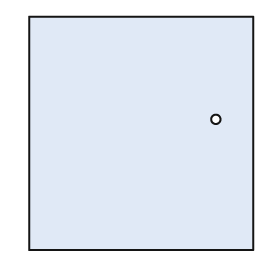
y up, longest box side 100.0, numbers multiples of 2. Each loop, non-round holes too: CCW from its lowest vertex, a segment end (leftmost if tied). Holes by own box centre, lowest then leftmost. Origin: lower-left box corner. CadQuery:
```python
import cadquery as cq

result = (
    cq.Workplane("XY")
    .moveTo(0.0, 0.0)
    .lineTo(96.0, 0.0)
    .lineTo(96.0, 100.0)
    .lineTo(0.0, 100.0)
    .close()
    .moveTo(80.0, 56.0)
    .circle(2.0)
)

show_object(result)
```